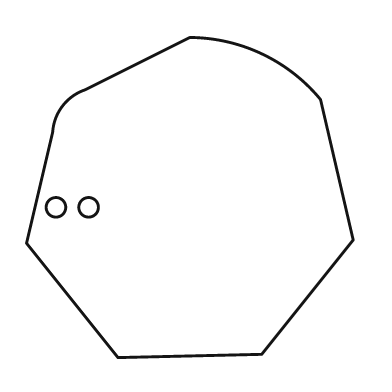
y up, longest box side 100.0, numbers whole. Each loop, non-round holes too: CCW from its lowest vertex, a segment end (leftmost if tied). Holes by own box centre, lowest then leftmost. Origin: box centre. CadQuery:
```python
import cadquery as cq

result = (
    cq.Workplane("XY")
    .moveTo(-22.0, -49.0)
    .lineTo(22.0, -48.0)
    .lineTo(50.0, -13.0)
    .lineTo(40.0, 30.0)
    .threePointArc((22.0, 44.0), (0.0, 49.0))
    .lineTo(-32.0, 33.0)
    .threePointArc((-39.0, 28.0), (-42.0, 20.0))
    .lineTo(-50.0, -14.0)
    .close()
    .moveTo(-41.0, -3.0)
    .circle(3.0)
    .moveTo(-31.0, -3.0)
    .circle(3.0)
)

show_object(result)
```